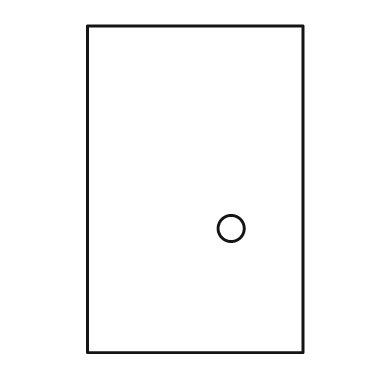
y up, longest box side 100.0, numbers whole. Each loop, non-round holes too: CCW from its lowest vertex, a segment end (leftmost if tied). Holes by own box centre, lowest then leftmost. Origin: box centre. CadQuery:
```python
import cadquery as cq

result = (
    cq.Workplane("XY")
    .moveTo(-33.0, -50.0)
    .lineTo(33.0, -50.0)
    .lineTo(33.0, 50.0)
    .lineTo(-33.0, 50.0)
    .close()
    .moveTo(11.0, -12.0)
    .circle(4.0)
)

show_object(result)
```